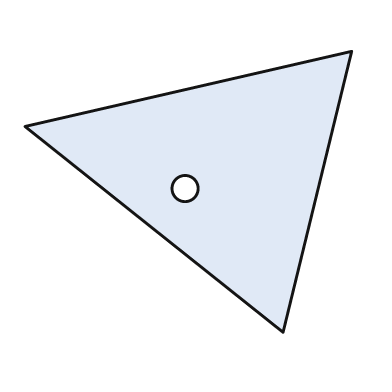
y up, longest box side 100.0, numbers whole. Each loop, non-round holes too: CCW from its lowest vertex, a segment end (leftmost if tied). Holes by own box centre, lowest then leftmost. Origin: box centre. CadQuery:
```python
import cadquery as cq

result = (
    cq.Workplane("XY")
    .moveTo(29.0, -43.0)
    .lineTo(50.0, 43.0)
    .lineTo(-50.0, 20.0)
    .close()
    .moveTo(-1.0, 1.0)
    .circle(4.0)
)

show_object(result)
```